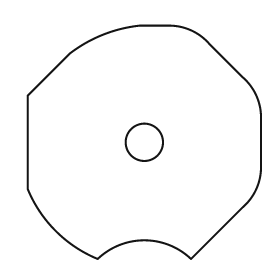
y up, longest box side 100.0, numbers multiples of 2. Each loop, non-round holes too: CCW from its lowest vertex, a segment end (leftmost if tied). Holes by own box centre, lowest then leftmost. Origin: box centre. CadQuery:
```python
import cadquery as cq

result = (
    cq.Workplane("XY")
    .moveTo(-20.0, -50.0)
    .threePointArc((0.0, -42.0), (20.0, -50.0))
    .lineTo(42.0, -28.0)
    .threePointArc((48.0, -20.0), (50.0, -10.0))
    .lineTo(50.0, 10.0)
    .threePointArc((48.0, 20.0), (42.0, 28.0))
    .lineTo(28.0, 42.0)
    .threePointArc((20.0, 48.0), (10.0, 50.0))
    .lineTo(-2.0, 50.0)
    .threePointArc((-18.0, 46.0), (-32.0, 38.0))
    .lineTo(-50.0, 20.0)
    .lineTo(-50.0, -20.0)
    .threePointArc((-38.0, -38.0), (-20.0, -50.0))
    .close()
    .moveTo(0.0, 0.0)
    .circle(8.0)
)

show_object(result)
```